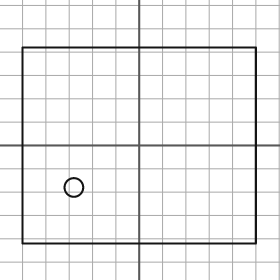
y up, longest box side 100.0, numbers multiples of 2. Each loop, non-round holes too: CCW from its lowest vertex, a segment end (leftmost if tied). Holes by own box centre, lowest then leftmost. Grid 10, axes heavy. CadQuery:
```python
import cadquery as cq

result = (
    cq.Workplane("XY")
    .moveTo(-50.0, -42.0)
    .lineTo(50.0, -42.0)
    .lineTo(50.0, 42.0)
    .lineTo(-50.0, 42.0)
    .close()
    .moveTo(-28.0, -18.0)
    .circle(4.0)
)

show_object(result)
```